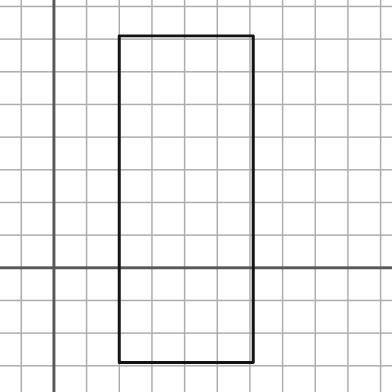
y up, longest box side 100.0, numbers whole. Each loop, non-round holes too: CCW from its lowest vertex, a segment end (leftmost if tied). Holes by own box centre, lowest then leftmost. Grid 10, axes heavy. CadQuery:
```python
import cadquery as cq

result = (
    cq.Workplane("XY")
    .moveTo(20.0, -29.0)
    .lineTo(61.0, -29.0)
    .lineTo(61.0, 71.0)
    .lineTo(20.0, 71.0)
    .close()
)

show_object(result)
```